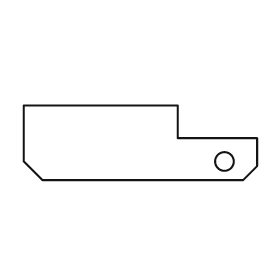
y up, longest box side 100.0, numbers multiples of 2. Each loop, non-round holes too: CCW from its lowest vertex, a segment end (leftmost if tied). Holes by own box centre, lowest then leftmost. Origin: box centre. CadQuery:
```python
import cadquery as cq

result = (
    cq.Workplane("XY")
    .moveTo(-42.0, -16.0)
    .lineTo(44.0, -16.0)
    .lineTo(50.0, -10.0)
    .lineTo(50.0, 2.0)
    .lineTo(16.0, 2.0)
    .lineTo(16.0, 16.0)
    .lineTo(-50.0, 16.0)
    .lineTo(-50.0, -8.0)
    .close()
    .moveTo(36.0, -8.0)
    .circle(4.0)
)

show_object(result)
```